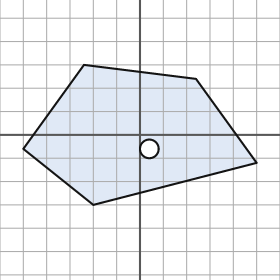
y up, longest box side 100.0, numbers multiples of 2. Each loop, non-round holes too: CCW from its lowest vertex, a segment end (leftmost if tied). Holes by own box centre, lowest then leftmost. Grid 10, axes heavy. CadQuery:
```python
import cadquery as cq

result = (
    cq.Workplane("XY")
    .moveTo(-20.0, -30.0)
    .lineTo(50.0, -12.0)
    .lineTo(24.0, 24.0)
    .lineTo(-24.0, 30.0)
    .lineTo(-50.0, -6.0)
    .close()
    .moveTo(4.0, -6.0)
    .circle(4.0)
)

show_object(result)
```